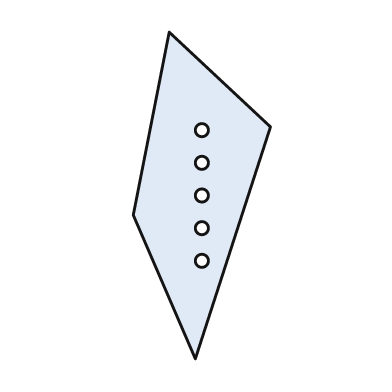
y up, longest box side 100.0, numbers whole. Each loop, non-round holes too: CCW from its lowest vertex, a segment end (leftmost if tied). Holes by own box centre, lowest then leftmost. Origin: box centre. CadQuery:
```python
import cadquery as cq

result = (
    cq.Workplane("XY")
    .moveTo(-2.0, -50.0)
    .lineTo(21.0, 21.0)
    .lineTo(-10.0, 50.0)
    .lineTo(-21.0, -6.0)
    .close()
    .moveTo(0.0, -20.0)
    .circle(2.0)
    .moveTo(0.0, -10.0)
    .circle(2.0)
    .moveTo(0.0, 0.0)
    .circle(2.0)
    .moveTo(0.0, 10.0)
    .circle(2.0)
    .moveTo(0.0, 20.0)
    .circle(2.0)
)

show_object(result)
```